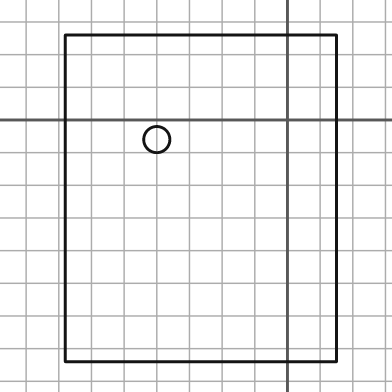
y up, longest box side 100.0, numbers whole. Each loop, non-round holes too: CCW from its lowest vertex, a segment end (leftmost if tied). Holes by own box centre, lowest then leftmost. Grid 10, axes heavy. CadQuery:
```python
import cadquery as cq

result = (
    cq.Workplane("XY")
    .moveTo(-68.0, -74.0)
    .lineTo(15.0, -74.0)
    .lineTo(15.0, 26.0)
    .lineTo(-68.0, 26.0)
    .close()
    .moveTo(-40.0, -6.0)
    .circle(4.0)
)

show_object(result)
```